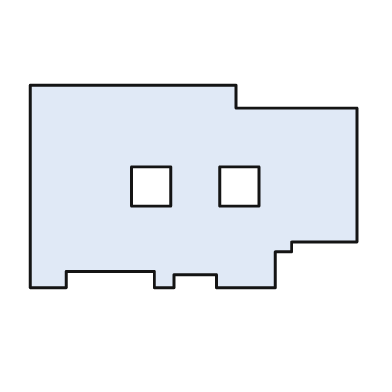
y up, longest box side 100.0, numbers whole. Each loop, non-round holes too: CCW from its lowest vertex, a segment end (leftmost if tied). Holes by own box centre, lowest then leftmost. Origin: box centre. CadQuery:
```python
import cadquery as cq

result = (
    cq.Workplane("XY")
    .moveTo(-50.0, -31.0)
    .lineTo(-39.0, -31.0)
    .lineTo(-39.0, -26.0)
    .lineTo(-12.0, -26.0)
    .lineTo(-12.0, -31.0)
    .lineTo(-6.0, -31.0)
    .lineTo(-6.0, -27.0)
    .lineTo(7.0, -27.0)
    .lineTo(7.0, -31.0)
    .lineTo(25.0, -31.0)
    .lineTo(25.0, -20.0)
    .lineTo(30.0, -20.0)
    .lineTo(30.0, -17.0)
    .lineTo(50.0, -17.0)
    .lineTo(50.0, 24.0)
    .lineTo(13.0, 24.0)
    .lineTo(13.0, 31.0)
    .lineTo(-50.0, 31.0)
    .close()
    .moveTo(-19.0, -6.0)
    .lineTo(-7.0, -6.0)
    .lineTo(-7.0, 6.0)
    .lineTo(-19.0, 6.0)
    .close()
    .moveTo(8.0, -6.0)
    .lineTo(20.0, -6.0)
    .lineTo(20.0, 6.0)
    .lineTo(8.0, 6.0)
    .close()
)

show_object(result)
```